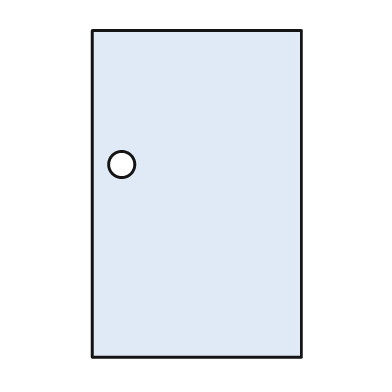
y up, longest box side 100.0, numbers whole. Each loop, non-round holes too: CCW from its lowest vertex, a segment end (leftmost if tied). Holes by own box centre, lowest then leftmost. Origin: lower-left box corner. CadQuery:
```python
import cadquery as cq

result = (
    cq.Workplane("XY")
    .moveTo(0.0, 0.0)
    .lineTo(64.0, 0.0)
    .lineTo(64.0, 100.0)
    .lineTo(0.0, 100.0)
    .close()
    .moveTo(9.0, 59.0)
    .circle(4.0)
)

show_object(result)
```